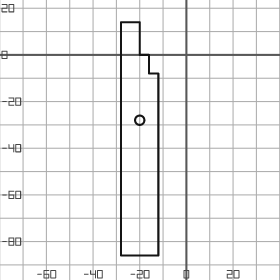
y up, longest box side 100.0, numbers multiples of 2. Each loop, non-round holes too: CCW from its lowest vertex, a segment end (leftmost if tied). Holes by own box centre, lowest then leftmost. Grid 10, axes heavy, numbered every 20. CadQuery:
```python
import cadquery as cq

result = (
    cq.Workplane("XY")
    .moveTo(-28.0, -86.0)
    .lineTo(-12.0, -86.0)
    .lineTo(-12.0, -8.0)
    .lineTo(-16.0, -8.0)
    .lineTo(-16.0, 0.0)
    .lineTo(-20.0, 0.0)
    .lineTo(-20.0, 14.0)
    .lineTo(-28.0, 14.0)
    .close()
    .moveTo(-20.0, -28.0)
    .circle(2.0)
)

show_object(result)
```